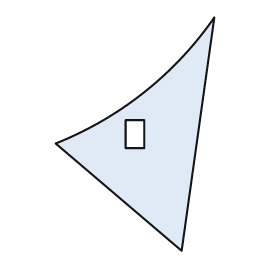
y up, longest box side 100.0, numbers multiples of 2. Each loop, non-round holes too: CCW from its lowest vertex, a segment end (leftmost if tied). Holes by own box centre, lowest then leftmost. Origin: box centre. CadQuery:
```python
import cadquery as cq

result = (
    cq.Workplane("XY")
    .moveTo(20.0, -50.0)
    .lineTo(34.0, 50.0)
    .threePointArc((4.0, 18.0), (-34.0, -4.0))
    .close()
    .moveTo(-4.0, -6.0)
    .lineTo(4.0, -6.0)
    .lineTo(4.0, 6.0)
    .lineTo(-4.0, 6.0)
    .close()
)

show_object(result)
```